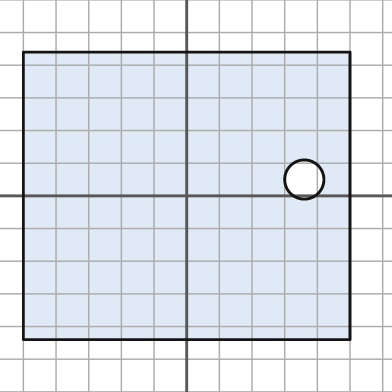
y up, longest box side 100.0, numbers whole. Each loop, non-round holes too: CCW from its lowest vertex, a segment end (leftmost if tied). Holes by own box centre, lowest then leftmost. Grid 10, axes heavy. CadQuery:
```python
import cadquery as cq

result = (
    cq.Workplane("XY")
    .moveTo(-50.0, -44.0)
    .lineTo(50.0, -44.0)
    .lineTo(50.0, 44.0)
    .lineTo(-50.0, 44.0)
    .close()
    .moveTo(36.0, 5.0)
    .circle(6.0)
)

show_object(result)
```